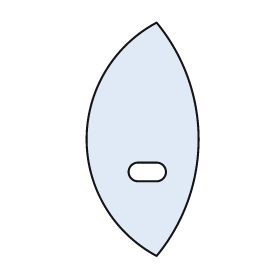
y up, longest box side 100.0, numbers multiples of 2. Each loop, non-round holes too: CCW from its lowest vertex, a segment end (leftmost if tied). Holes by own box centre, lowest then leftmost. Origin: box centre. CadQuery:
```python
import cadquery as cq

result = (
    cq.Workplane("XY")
    .moveTo(6.0, -50.0)
    .threePointArc((24.0, 0.0), (6.0, 50.0))
    .threePointArc((-24.0, 0.0), (6.0, -50.0))
    .close()
    .moveTo(-2.0, -18.0)
    .lineTo(6.0, -18.0)
    .threePointArc((10.0, -14.0), (6.0, -10.0))
    .lineTo(-2.0, -10.0)
    .threePointArc((-6.0, -14.0), (-2.0, -18.0))
    .close()
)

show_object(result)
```